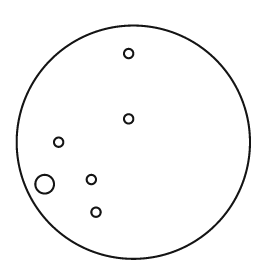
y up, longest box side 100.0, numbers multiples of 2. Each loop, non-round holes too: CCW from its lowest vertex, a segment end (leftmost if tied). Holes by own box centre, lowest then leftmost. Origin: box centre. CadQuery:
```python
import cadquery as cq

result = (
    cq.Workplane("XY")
    .moveTo(0.0, 0.0)
    .circle(50.0)
    .moveTo(-16.0, -30.0)
    .circle(2.0)
    .moveTo(-38.0, -18.0)
    .circle(4.0)
    .moveTo(-18.0, -16.0)
    .circle(2.0)
    .moveTo(-32.0, 0.0)
    .circle(2.0)
    .moveTo(-2.0, 10.0)
    .circle(2.0)
    .moveTo(-2.0, 38.0)
    .circle(2.0)
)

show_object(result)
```